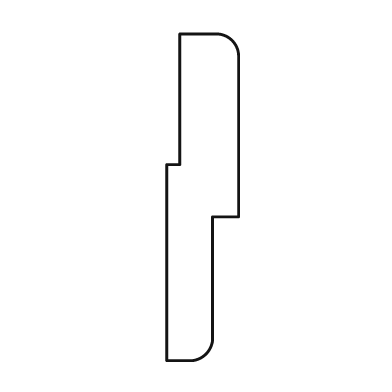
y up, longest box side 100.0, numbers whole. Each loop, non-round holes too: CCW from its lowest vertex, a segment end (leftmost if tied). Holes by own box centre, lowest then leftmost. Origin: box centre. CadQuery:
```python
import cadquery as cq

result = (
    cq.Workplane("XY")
    .moveTo(-11.0, -50.0)
    .lineTo(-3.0, -50.0)
    .threePointArc((1.0, -48.0), (3.0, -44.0))
    .lineTo(3.0, -6.0)
    .lineTo(11.0, -6.0)
    .lineTo(11.0, 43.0)
    .threePointArc((9.0, 48.0), (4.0, 50.0))
    .lineTo(-7.0, 50.0)
    .lineTo(-7.0, 10.0)
    .lineTo(-11.0, 10.0)
    .close()
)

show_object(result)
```